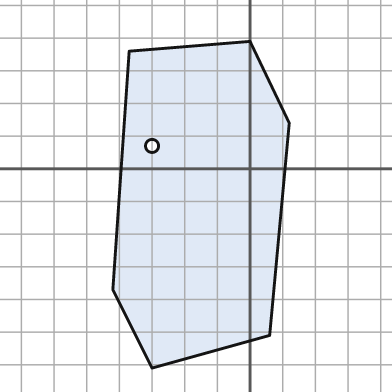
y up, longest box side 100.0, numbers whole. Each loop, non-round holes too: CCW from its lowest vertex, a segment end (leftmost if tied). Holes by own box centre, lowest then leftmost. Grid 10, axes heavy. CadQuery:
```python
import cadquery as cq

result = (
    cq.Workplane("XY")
    .moveTo(-30.0, -61.0)
    .lineTo(6.0, -51.0)
    .lineTo(12.0, 14.0)
    .lineTo(0.0, 39.0)
    .lineTo(-37.0, 36.0)
    .lineTo(-42.0, -37.0)
    .close()
    .moveTo(-30.0, 7.0)
    .circle(2.0)
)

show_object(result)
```